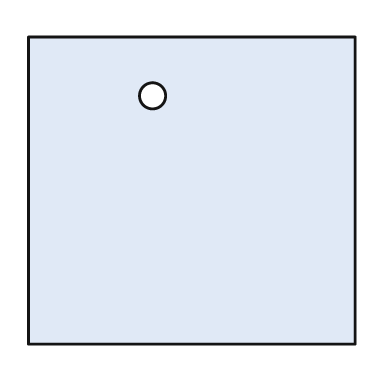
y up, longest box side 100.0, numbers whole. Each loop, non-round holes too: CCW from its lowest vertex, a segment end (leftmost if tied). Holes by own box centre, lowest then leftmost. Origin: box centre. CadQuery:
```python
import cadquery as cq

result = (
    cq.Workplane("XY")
    .moveTo(-50.0, -47.0)
    .lineTo(50.0, -47.0)
    .lineTo(50.0, 47.0)
    .lineTo(-50.0, 47.0)
    .close()
    .moveTo(-12.0, 29.0)
    .circle(4.0)
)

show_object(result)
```